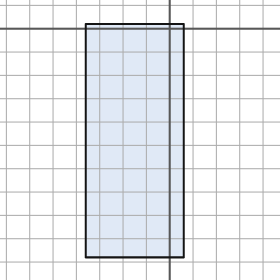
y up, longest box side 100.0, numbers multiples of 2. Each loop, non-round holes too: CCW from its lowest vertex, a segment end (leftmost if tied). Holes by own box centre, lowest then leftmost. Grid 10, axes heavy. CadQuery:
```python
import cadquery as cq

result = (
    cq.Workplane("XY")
    .moveTo(-36.0, -98.0)
    .lineTo(6.0, -98.0)
    .lineTo(6.0, 2.0)
    .lineTo(-36.0, 2.0)
    .close()
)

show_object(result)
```